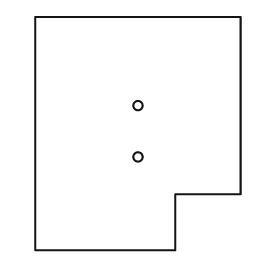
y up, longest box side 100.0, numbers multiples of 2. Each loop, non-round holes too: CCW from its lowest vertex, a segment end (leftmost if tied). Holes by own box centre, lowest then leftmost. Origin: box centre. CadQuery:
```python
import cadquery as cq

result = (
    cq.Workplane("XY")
    .moveTo(-44.0, -50.0)
    .lineTo(16.0, -50.0)
    .lineTo(16.0, -26.0)
    .lineTo(44.0, -26.0)
    .lineTo(44.0, 50.0)
    .lineTo(-44.0, 50.0)
    .close()
    .moveTo(0.0, -10.0)
    .circle(2.0)
    .moveTo(0.0, 12.0)
    .circle(2.0)
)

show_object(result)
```